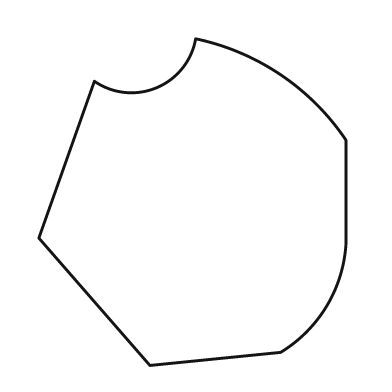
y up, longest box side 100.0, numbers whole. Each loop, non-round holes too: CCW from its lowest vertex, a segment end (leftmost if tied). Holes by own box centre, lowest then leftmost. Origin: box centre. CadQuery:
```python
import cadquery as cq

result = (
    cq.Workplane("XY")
    .moveTo(-13.0, -50.0)
    .lineTo(27.0, -46.0)
    .threePointArc((41.0, -32.0), (47.0, -13.0))
    .lineTo(47.0, 19.0)
    .threePointArc((27.0, 39.0), (1.0, 50.0))
    .threePointArc((-11.0, 35.0), (-30.0, 37.0))
    .lineTo(-47.0, -11.0)
    .close()
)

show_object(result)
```